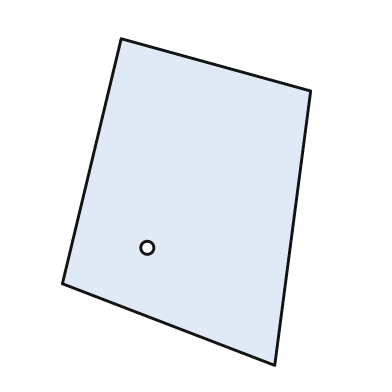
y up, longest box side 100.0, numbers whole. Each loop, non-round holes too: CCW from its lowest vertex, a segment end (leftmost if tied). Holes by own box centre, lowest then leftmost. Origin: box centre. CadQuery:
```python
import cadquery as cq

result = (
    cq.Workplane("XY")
    .moveTo(27.0, -50.0)
    .lineTo(38.0, 34.0)
    .lineTo(-20.0, 50.0)
    .lineTo(-38.0, -25.0)
    .close()
    .moveTo(-12.0, -14.0)
    .circle(2.0)
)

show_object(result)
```